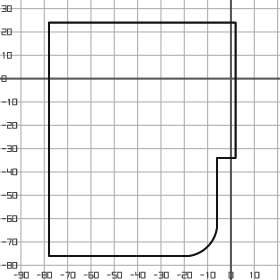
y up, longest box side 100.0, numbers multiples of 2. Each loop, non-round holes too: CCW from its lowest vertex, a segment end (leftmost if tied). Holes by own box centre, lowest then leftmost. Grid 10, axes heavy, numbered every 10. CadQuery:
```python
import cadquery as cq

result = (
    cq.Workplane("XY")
    .moveTo(-78.0, -76.0)
    .lineTo(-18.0, -76.0)
    .threePointArc((-10.0, -72.0), (-6.0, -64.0))
    .lineTo(-6.0, -34.0)
    .lineTo(2.0, -34.0)
    .lineTo(2.0, 24.0)
    .lineTo(-78.0, 24.0)
    .close()
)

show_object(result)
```